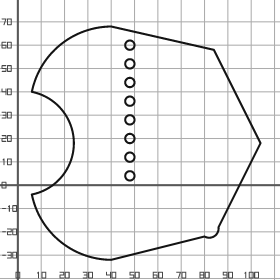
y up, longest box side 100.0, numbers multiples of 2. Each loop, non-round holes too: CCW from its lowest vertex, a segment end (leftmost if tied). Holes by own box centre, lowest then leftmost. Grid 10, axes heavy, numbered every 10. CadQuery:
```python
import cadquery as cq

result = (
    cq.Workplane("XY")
    .moveTo(40.0, -32.0)
    .lineTo(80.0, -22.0)
    .threePointArc((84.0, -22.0), (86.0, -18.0))
    .lineTo(104.0, 18.0)
    .lineTo(84.0, 58.0)
    .lineTo(40.0, 68.0)
    .threePointArc((18.0, 60.0), (6.0, 40.0))
    .threePointArc((24.0, 18.0), (6.0, -4.0))
    .threePointArc((18.0, -24.0), (40.0, -32.0))
    .close()
    .moveTo(48.0, 4.0)
    .circle(2.0)
    .moveTo(48.0, 12.0)
    .circle(2.0)
    .moveTo(48.0, 20.0)
    .circle(2.0)
    .moveTo(48.0, 28.0)
    .circle(2.0)
    .moveTo(48.0, 36.0)
    .circle(2.0)
    .moveTo(48.0, 44.0)
    .circle(2.0)
    .moveTo(48.0, 52.0)
    .circle(2.0)
    .moveTo(48.0, 60.0)
    .circle(2.0)
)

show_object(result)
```